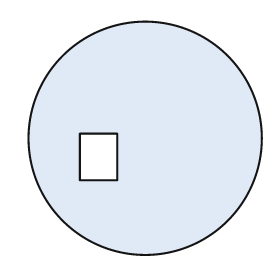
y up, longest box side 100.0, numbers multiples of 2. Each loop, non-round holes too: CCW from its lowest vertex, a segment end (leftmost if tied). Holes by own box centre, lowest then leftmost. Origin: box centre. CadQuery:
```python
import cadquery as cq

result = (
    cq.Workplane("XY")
    .moveTo(0.0, 0.0)
    .circle(50.0)
    .moveTo(-28.0, -18.0)
    .lineTo(-12.0, -18.0)
    .lineTo(-12.0, 2.0)
    .lineTo(-28.0, 2.0)
    .close()
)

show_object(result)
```